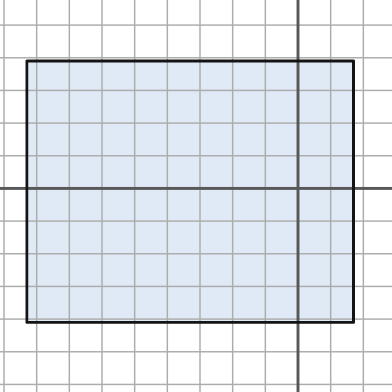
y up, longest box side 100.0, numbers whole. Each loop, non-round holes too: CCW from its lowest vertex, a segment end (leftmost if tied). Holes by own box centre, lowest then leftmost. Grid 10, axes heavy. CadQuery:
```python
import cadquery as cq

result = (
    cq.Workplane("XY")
    .moveTo(-83.0, -41.0)
    .lineTo(17.0, -41.0)
    .lineTo(17.0, 39.0)
    .lineTo(-83.0, 39.0)
    .close()
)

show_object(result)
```